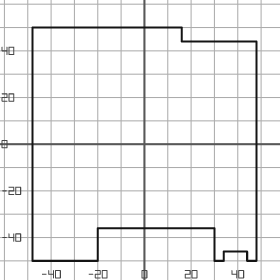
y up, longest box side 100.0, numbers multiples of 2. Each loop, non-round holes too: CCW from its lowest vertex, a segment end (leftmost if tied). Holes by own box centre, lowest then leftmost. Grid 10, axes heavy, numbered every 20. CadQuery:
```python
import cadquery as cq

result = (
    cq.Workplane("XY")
    .moveTo(-48.0, -50.0)
    .lineTo(-20.0, -50.0)
    .lineTo(-20.0, -36.0)
    .lineTo(30.0, -36.0)
    .lineTo(30.0, -50.0)
    .lineTo(34.0, -50.0)
    .lineTo(34.0, -46.0)
    .lineTo(44.0, -46.0)
    .lineTo(44.0, -50.0)
    .lineTo(48.0, -50.0)
    .lineTo(48.0, 44.0)
    .lineTo(16.0, 44.0)
    .lineTo(16.0, 50.0)
    .lineTo(-48.0, 50.0)
    .close()
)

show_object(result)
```